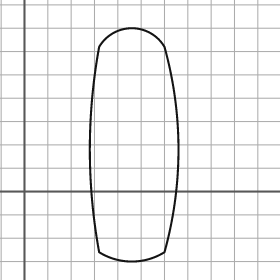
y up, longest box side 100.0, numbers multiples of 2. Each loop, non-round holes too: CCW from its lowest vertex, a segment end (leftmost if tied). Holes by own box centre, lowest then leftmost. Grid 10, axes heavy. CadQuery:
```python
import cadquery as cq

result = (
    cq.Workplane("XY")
    .moveTo(32.0, -26.0)
    .threePointArc((46.0, -30.0), (60.0, -26.0))
    .threePointArc((66.0, 18.0), (60.0, 62.0))
    .threePointArc((46.0, 70.0), (32.0, 62.0))
    .threePointArc((28.0, 18.0), (32.0, -26.0))
    .close()
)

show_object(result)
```